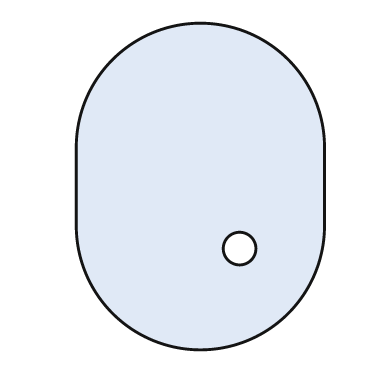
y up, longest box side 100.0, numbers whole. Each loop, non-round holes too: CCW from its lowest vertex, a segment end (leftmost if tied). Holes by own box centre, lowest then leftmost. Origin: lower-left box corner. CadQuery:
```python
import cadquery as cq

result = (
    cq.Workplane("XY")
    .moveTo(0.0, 38.0)
    .threePointArc((38.0, 0.0), (76.0, 38.0))
    .lineTo(76.0, 62.0)
    .threePointArc((38.0, 100.0), (0.0, 62.0))
    .close()
    .moveTo(50.0, 31.0)
    .circle(5.0)
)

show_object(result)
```